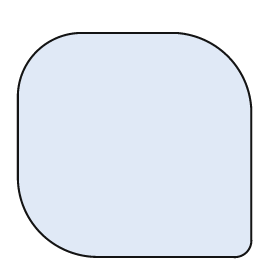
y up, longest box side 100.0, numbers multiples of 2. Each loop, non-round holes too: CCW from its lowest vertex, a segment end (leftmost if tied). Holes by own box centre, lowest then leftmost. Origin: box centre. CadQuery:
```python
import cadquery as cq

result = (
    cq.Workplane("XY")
    .moveTo(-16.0, -48.0)
    .lineTo(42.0, -48.0)
    .threePointArc((48.0, -46.0), (50.0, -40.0))
    .lineTo(50.0, 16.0)
    .threePointArc((40.0, 38.0), (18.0, 48.0))
    .lineTo(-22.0, 48.0)
    .threePointArc((-42.0, 40.0), (-50.0, 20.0))
    .lineTo(-50.0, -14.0)
    .threePointArc((-40.0, -38.0), (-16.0, -48.0))
    .close()
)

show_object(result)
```